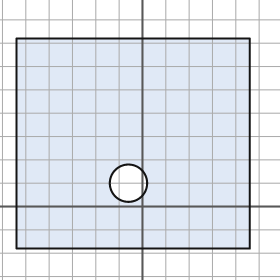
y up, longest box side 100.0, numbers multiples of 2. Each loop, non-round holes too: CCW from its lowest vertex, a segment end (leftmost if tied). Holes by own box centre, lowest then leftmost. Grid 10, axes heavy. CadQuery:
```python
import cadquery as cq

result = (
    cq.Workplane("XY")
    .moveTo(-54.0, -18.0)
    .lineTo(46.0, -18.0)
    .lineTo(46.0, 72.0)
    .lineTo(-54.0, 72.0)
    .close()
    .moveTo(-6.0, 10.0)
    .circle(8.0)
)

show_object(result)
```